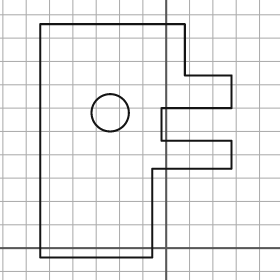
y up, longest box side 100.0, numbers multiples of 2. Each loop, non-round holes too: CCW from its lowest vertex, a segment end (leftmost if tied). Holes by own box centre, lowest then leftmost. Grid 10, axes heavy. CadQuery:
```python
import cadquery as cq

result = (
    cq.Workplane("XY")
    .moveTo(-54.0, -4.0)
    .lineTo(-6.0, -4.0)
    .lineTo(-6.0, 34.0)
    .lineTo(28.0, 34.0)
    .lineTo(28.0, 46.0)
    .lineTo(-2.0, 46.0)
    .lineTo(-2.0, 60.0)
    .lineTo(28.0, 60.0)
    .lineTo(28.0, 74.0)
    .lineTo(8.0, 74.0)
    .lineTo(8.0, 96.0)
    .lineTo(-54.0, 96.0)
    .close()
    .moveTo(-24.0, 58.0)
    .circle(8.0)
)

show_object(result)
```